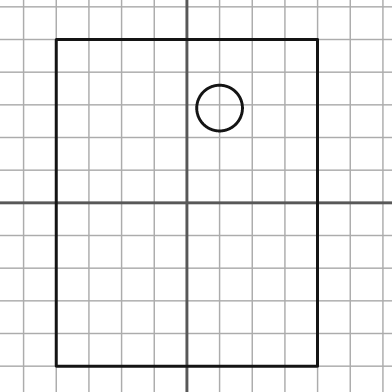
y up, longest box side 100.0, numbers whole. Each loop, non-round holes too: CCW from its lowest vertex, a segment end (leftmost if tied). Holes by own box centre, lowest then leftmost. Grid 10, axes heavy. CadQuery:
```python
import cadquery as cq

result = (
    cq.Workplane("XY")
    .moveTo(-40.0, -50.0)
    .lineTo(40.0, -50.0)
    .lineTo(40.0, 50.0)
    .lineTo(-40.0, 50.0)
    .close()
    .moveTo(10.0, 29.0)
    .circle(7.0)
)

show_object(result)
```